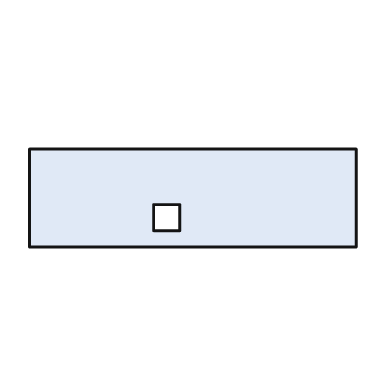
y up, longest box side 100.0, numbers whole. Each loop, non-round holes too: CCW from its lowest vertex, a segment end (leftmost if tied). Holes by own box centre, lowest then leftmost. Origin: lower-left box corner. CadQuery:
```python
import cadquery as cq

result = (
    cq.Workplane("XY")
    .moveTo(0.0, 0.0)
    .lineTo(100.0, 0.0)
    .lineTo(100.0, 30.0)
    .lineTo(0.0, 30.0)
    .close()
    .moveTo(38.0, 5.0)
    .lineTo(46.0, 5.0)
    .lineTo(46.0, 13.0)
    .lineTo(38.0, 13.0)
    .close()
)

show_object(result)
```